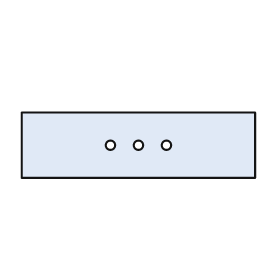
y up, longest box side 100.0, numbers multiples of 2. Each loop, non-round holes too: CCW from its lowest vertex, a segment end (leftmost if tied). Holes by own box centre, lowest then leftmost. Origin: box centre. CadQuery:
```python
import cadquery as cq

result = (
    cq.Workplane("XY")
    .moveTo(-50.0, -14.0)
    .lineTo(50.0, -14.0)
    .lineTo(50.0, 14.0)
    .lineTo(-50.0, 14.0)
    .close()
    .moveTo(-12.0, 0.0)
    .circle(2.0)
    .moveTo(0.0, 0.0)
    .circle(2.0)
    .moveTo(12.0, 0.0)
    .circle(2.0)
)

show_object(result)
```